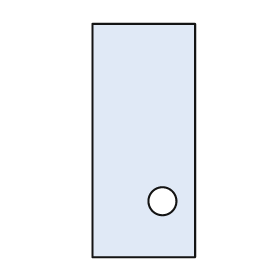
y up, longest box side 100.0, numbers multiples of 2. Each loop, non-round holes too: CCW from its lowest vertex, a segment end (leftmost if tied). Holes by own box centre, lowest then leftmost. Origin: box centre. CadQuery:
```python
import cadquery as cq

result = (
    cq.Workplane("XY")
    .moveTo(-22.0, -50.0)
    .lineTo(22.0, -50.0)
    .lineTo(22.0, 50.0)
    .lineTo(-22.0, 50.0)
    .close()
    .moveTo(8.0, -26.0)
    .circle(6.0)
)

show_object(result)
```